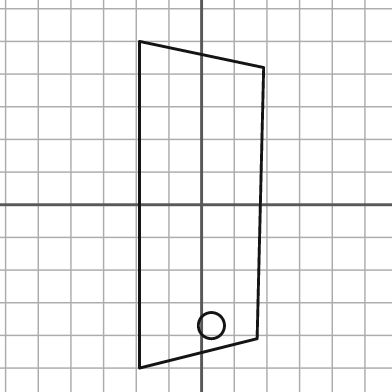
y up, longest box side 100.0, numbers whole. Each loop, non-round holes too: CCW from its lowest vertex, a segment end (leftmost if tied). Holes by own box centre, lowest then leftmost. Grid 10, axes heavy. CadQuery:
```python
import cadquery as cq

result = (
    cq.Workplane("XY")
    .moveTo(-19.0, -50.0)
    .lineTo(17.0, -41.0)
    .lineTo(19.0, 42.0)
    .lineTo(-19.0, 50.0)
    .close()
    .moveTo(3.0, -37.0)
    .circle(4.0)
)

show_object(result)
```